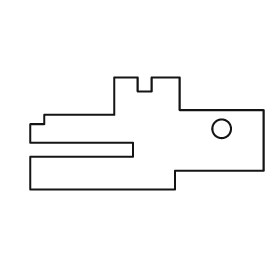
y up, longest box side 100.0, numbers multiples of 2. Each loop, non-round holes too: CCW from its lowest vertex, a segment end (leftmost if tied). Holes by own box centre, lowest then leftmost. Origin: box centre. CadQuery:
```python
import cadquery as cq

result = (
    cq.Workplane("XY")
    .moveTo(-50.0, -24.0)
    .lineTo(12.0, -24.0)
    .lineTo(12.0, -16.0)
    .lineTo(50.0, -16.0)
    .lineTo(50.0, 10.0)
    .lineTo(14.0, 10.0)
    .lineTo(14.0, 24.0)
    .lineTo(2.0, 24.0)
    .lineTo(2.0, 18.0)
    .lineTo(-4.0, 18.0)
    .lineTo(-4.0, 24.0)
    .lineTo(-14.0, 24.0)
    .lineTo(-14.0, 8.0)
    .lineTo(-44.0, 8.0)
    .lineTo(-44.0, 4.0)
    .lineTo(-50.0, 4.0)
    .lineTo(-50.0, -4.0)
    .lineTo(-6.0, -4.0)
    .lineTo(-6.0, -10.0)
    .lineTo(-50.0, -10.0)
    .close()
    .moveTo(32.0, 2.0)
    .circle(4.0)
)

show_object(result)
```